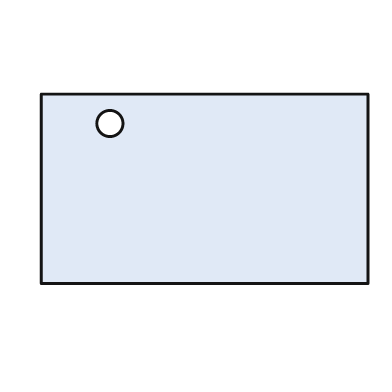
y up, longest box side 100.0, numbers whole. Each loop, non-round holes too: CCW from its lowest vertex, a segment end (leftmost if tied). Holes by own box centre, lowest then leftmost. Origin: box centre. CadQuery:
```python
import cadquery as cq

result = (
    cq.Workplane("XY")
    .moveTo(-50.0, -29.0)
    .lineTo(50.0, -29.0)
    .lineTo(50.0, 29.0)
    .lineTo(-50.0, 29.0)
    .close()
    .moveTo(-29.0, 20.0)
    .circle(4.0)
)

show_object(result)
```